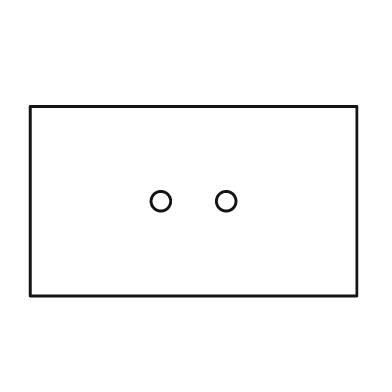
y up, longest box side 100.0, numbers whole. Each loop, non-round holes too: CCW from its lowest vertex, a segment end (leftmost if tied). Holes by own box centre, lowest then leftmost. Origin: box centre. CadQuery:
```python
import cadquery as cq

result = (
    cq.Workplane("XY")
    .moveTo(-50.0, -29.0)
    .lineTo(50.0, -29.0)
    .lineTo(50.0, 29.0)
    .lineTo(-50.0, 29.0)
    .close()
    .moveTo(-10.0, 0.0)
    .circle(3.0)
    .moveTo(10.0, 0.0)
    .circle(3.0)
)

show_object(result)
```